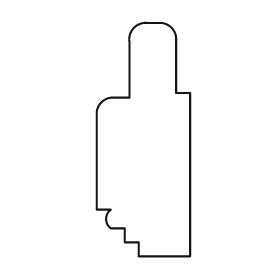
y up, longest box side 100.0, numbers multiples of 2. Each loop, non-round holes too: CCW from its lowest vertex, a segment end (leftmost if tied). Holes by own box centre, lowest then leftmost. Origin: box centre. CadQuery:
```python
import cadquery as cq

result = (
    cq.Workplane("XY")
    .moveTo(-2.0, -50.0)
    .lineTo(20.0, -50.0)
    .lineTo(20.0, 20.0)
    .lineTo(14.0, 20.0)
    .lineTo(14.0, 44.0)
    .threePointArc((12.0, 48.0), (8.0, 50.0))
    .lineTo(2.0, 50.0)
    .threePointArc((-4.0, 48.0), (-6.0, 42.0))
    .lineTo(-6.0, 18.0)
    .lineTo(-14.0, 18.0)
    .threePointArc((-18.0, 16.0), (-20.0, 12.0))
    .lineTo(-20.0, -30.0)
    .lineTo(-14.0, -30.0)
    .threePointArc((-16.0, -34.0), (-14.0, -38.0))
    .lineTo(-8.0, -38.0)
    .lineTo(-8.0, -44.0)
    .lineTo(-2.0, -44.0)
    .close()
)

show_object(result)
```